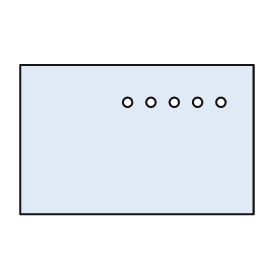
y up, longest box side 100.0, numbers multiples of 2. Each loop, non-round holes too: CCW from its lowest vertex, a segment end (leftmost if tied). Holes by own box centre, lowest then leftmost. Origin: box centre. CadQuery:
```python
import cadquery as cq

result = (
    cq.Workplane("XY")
    .moveTo(-50.0, -32.0)
    .lineTo(50.0, -32.0)
    .lineTo(50.0, 32.0)
    .lineTo(-50.0, 32.0)
    .close()
    .moveTo(-4.0, 16.0)
    .circle(2.0)
    .moveTo(6.0, 16.0)
    .circle(2.0)
    .moveTo(16.0, 16.0)
    .circle(2.0)
    .moveTo(26.0, 16.0)
    .circle(2.0)
    .moveTo(36.0, 16.0)
    .circle(2.0)
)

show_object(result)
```